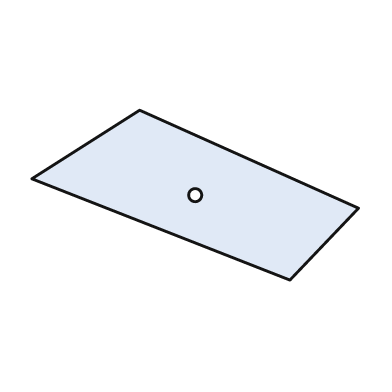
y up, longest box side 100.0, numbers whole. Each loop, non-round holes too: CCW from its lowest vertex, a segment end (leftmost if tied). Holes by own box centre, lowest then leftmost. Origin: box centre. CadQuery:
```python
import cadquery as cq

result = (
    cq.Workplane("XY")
    .moveTo(29.0, -26.0)
    .lineTo(50.0, -4.0)
    .lineTo(-17.0, 26.0)
    .lineTo(-50.0, 5.0)
    .close()
    .moveTo(0.0, 0.0)
    .circle(2.0)
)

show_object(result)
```